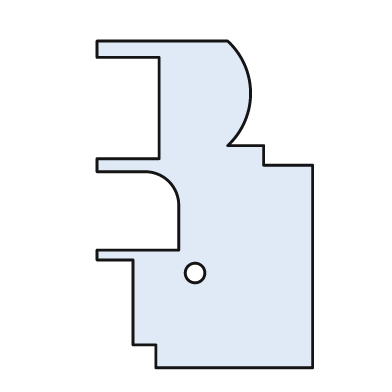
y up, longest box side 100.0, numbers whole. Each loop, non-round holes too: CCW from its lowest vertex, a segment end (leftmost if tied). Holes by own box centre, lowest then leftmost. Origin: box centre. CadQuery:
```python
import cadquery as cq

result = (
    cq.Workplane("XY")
    .moveTo(-15.0, -50.0)
    .lineTo(33.0, -50.0)
    .lineTo(33.0, 12.0)
    .lineTo(18.0, 12.0)
    .lineTo(18.0, 18.0)
    .lineTo(7.0, 18.0)
    .threePointArc((14.0, 34.0), (7.0, 50.0))
    .lineTo(-33.0, 50.0)
    .lineTo(-33.0, 45.0)
    .lineTo(-14.0, 45.0)
    .lineTo(-14.0, 14.0)
    .lineTo(-33.0, 14.0)
    .lineTo(-33.0, 10.0)
    .lineTo(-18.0, 10.0)
    .threePointArc((-11.0, 7.0), (-8.0, 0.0))
    .lineTo(-8.0, -14.0)
    .lineTo(-33.0, -14.0)
    .lineTo(-33.0, -17.0)
    .lineTo(-22.0, -17.0)
    .lineTo(-22.0, -43.0)
    .lineTo(-15.0, -43.0)
    .close()
    .moveTo(-3.0, -21.0)
    .circle(3.0)
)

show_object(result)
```